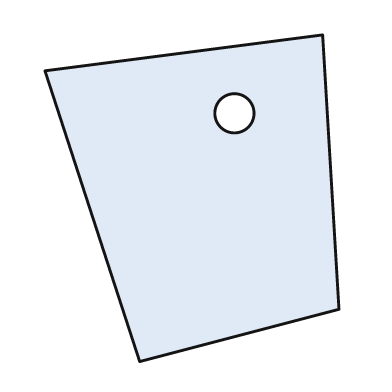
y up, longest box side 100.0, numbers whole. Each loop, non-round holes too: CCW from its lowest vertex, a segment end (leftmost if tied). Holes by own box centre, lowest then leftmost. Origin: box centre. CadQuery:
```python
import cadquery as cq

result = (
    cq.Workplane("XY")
    .moveTo(-16.0, -50.0)
    .lineTo(45.0, -34.0)
    .lineTo(40.0, 50.0)
    .lineTo(-45.0, 39.0)
    .close()
    .moveTo(13.0, 26.0)
    .circle(6.0)
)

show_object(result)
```